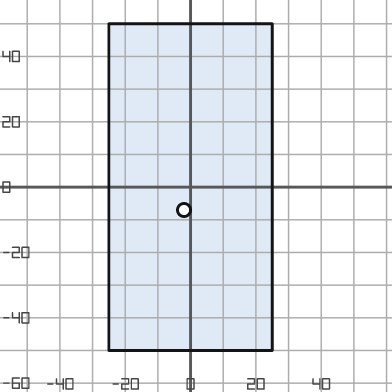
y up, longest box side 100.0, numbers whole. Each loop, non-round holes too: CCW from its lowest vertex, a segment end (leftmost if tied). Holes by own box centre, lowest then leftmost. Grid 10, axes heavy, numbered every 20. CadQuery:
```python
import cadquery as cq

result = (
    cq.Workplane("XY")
    .moveTo(-25.0, -50.0)
    .lineTo(25.0, -50.0)
    .lineTo(25.0, 50.0)
    .lineTo(-25.0, 50.0)
    .close()
    .moveTo(-2.0, -7.0)
    .circle(2.0)
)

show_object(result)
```